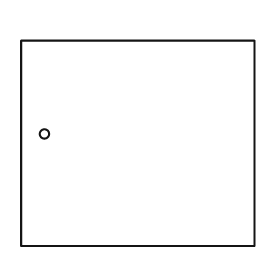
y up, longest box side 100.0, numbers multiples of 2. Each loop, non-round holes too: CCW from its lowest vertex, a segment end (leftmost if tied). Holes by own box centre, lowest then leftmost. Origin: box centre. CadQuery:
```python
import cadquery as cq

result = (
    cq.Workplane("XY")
    .moveTo(-50.0, -44.0)
    .lineTo(50.0, -44.0)
    .lineTo(50.0, 44.0)
    .lineTo(-50.0, 44.0)
    .close()
    .moveTo(-40.0, 4.0)
    .circle(2.0)
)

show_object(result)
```